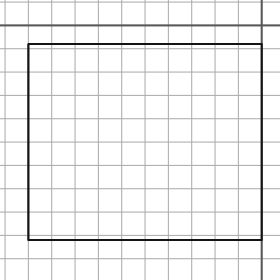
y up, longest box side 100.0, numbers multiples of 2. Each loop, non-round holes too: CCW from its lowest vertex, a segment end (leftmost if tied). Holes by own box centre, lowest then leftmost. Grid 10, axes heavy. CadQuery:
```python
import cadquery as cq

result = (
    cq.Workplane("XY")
    .moveTo(-100.0, -92.0)
    .lineTo(0.0, -92.0)
    .lineTo(0.0, -8.0)
    .lineTo(-100.0, -8.0)
    .close()
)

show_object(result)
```